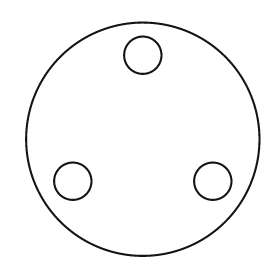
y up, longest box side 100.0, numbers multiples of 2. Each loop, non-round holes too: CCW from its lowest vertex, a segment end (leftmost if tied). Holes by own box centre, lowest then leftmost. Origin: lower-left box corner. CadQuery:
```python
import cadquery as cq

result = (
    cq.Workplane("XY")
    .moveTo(50.0, 50.0)
    .circle(50.0)
    .moveTo(20.0, 32.0)
    .circle(8.0)
    .moveTo(80.0, 32.0)
    .circle(8.0)
    .moveTo(50.0, 86.0)
    .circle(8.0)
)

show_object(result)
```